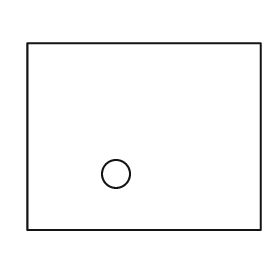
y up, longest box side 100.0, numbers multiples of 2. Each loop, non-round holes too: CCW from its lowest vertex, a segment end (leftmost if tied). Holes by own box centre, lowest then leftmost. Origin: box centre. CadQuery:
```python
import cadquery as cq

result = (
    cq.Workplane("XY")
    .moveTo(-50.0, -40.0)
    .lineTo(50.0, -40.0)
    .lineTo(50.0, 40.0)
    .lineTo(-50.0, 40.0)
    .close()
    .moveTo(-12.0, -16.0)
    .circle(6.0)
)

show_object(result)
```